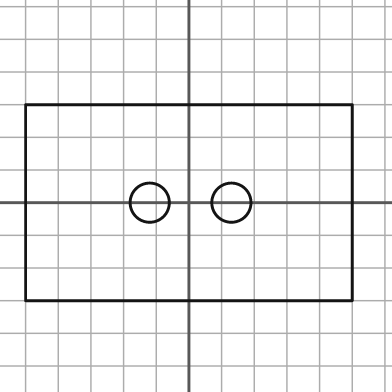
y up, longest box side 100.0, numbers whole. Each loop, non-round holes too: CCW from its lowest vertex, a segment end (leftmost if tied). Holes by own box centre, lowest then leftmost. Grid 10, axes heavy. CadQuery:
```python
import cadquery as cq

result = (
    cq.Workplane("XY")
    .moveTo(-50.0, -30.0)
    .lineTo(50.0, -30.0)
    .lineTo(50.0, 30.0)
    .lineTo(-50.0, 30.0)
    .close()
    .moveTo(-12.0, 0.0)
    .circle(6.0)
    .moveTo(13.0, 0.0)
    .circle(6.0)
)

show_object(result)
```